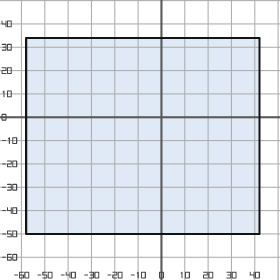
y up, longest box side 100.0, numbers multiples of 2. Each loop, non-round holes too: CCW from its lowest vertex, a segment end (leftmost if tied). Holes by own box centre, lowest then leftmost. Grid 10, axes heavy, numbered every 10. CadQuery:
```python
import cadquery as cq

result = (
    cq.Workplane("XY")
    .moveTo(-58.0, -50.0)
    .lineTo(42.0, -50.0)
    .lineTo(42.0, 34.0)
    .lineTo(-58.0, 34.0)
    .close()
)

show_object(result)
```